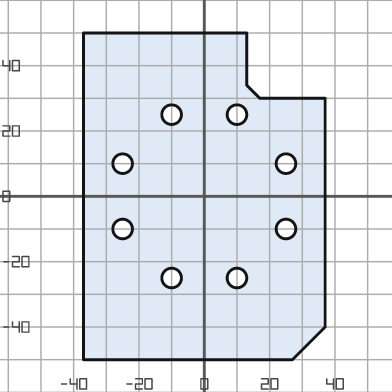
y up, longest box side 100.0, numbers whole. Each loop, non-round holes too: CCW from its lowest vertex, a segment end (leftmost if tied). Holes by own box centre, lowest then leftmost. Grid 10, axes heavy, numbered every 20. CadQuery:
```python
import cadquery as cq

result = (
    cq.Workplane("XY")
    .moveTo(-37.0, -50.0)
    .lineTo(27.0, -50.0)
    .lineTo(37.0, -40.0)
    .lineTo(37.0, 30.0)
    .lineTo(17.0, 30.0)
    .lineTo(13.0, 34.0)
    .lineTo(13.0, 50.0)
    .lineTo(-37.0, 50.0)
    .close()
    .moveTo(-10.0, -25.0)
    .circle(3.0)
    .moveTo(10.0, -25.0)
    .circle(3.0)
    .moveTo(-25.0, -10.0)
    .circle(3.0)
    .moveTo(25.0, -10.0)
    .circle(3.0)
    .moveTo(-25.0, 10.0)
    .circle(3.0)
    .moveTo(25.0, 10.0)
    .circle(3.0)
    .moveTo(-10.0, 25.0)
    .circle(3.0)
    .moveTo(10.0, 25.0)
    .circle(3.0)
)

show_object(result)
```